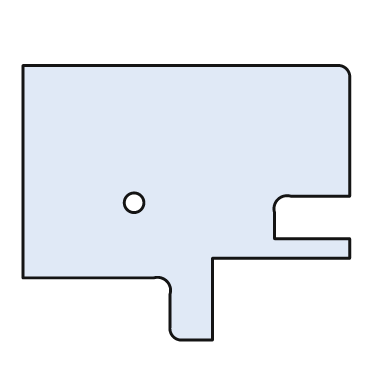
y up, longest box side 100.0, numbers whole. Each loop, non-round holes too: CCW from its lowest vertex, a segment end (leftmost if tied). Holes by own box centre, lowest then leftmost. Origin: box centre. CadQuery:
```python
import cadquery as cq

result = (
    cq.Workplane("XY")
    .moveTo(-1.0, -42.0)
    .lineTo(8.0, -42.0)
    .lineTo(8.0, -17.0)
    .lineTo(50.0, -17.0)
    .lineTo(50.0, -11.0)
    .lineTo(27.0, -11.0)
    .lineTo(27.0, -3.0)
    .threePointArc((28.0, 1.0), (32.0, 2.0))
    .lineTo(50.0, 2.0)
    .lineTo(50.0, 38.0)
    .threePointArc((49.0, 41.0), (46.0, 42.0))
    .lineTo(-50.0, 42.0)
    .lineTo(-50.0, -23.0)
    .lineTo(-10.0, -23.0)
    .threePointArc((-6.0, -24.0), (-5.0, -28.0))
    .lineTo(-5.0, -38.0)
    .threePointArc((-4.0, -41.0), (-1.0, -42.0))
    .close()
    .moveTo(-16.0, 0.0)
    .circle(3.0)
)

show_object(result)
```